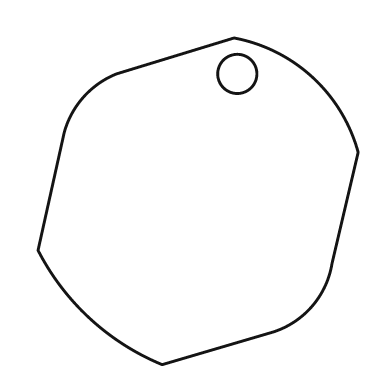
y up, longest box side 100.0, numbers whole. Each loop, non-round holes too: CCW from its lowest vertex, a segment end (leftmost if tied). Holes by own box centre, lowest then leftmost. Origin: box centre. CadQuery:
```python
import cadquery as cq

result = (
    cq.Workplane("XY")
    .moveTo(-11.0, -50.0)
    .lineTo(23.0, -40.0)
    .threePointArc((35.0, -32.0), (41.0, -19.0))
    .lineTo(49.0, 15.0)
    .threePointArc((35.0, 38.0), (11.0, 50.0))
    .lineTo(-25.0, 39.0)
    .threePointArc((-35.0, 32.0), (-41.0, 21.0))
    .lineTo(-49.0, -15.0)
    .threePointArc((-33.0, -36.0), (-11.0, -50.0))
    .close()
    .moveTo(12.0, 39.0)
    .circle(6.0)
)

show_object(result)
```